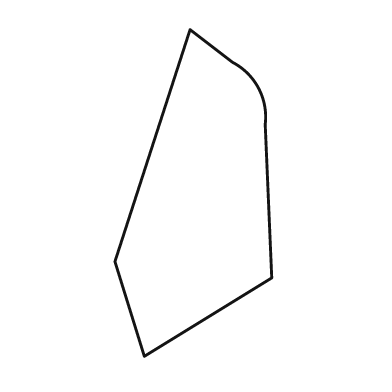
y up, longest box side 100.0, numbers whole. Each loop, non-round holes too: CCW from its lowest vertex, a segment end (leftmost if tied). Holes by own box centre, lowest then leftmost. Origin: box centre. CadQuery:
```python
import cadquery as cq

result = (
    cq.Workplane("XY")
    .moveTo(-15.0, -50.0)
    .lineTo(24.0, -26.0)
    .lineTo(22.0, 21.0)
    .threePointArc((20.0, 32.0), (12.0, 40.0))
    .lineTo(-1.0, 50.0)
    .lineTo(-24.0, -21.0)
    .close()
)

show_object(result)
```